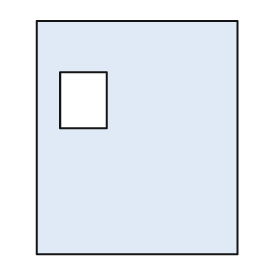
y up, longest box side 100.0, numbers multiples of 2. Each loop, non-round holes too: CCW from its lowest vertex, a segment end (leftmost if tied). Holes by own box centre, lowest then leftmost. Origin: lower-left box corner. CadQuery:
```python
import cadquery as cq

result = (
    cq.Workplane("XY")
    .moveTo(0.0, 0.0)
    .lineTo(86.0, 0.0)
    .lineTo(86.0, 100.0)
    .lineTo(0.0, 100.0)
    .close()
    .moveTo(10.0, 54.0)
    .lineTo(30.0, 54.0)
    .lineTo(30.0, 78.0)
    .lineTo(10.0, 78.0)
    .close()
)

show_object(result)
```